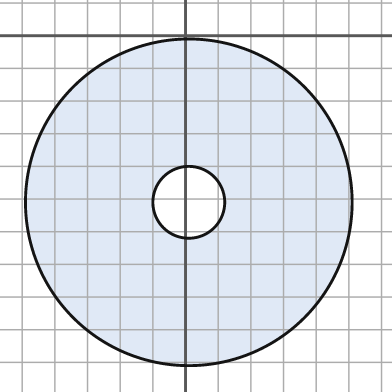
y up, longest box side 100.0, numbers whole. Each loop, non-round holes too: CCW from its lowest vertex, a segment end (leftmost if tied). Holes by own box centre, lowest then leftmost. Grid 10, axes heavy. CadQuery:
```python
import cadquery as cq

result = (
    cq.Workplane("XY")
    .moveTo(1.0, -51.0)
    .circle(50.0)
    .moveTo(1.0, -51.0)
    .circle(11.0)
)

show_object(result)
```